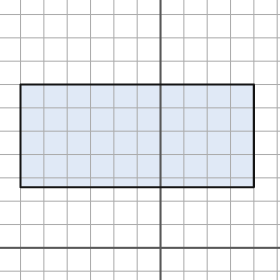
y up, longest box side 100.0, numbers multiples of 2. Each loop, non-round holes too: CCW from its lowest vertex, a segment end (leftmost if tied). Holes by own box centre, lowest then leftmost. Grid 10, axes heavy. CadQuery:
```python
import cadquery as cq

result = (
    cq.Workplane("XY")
    .moveTo(-60.0, 26.0)
    .lineTo(40.0, 26.0)
    .lineTo(40.0, 70.0)
    .lineTo(-60.0, 70.0)
    .close()
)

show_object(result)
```